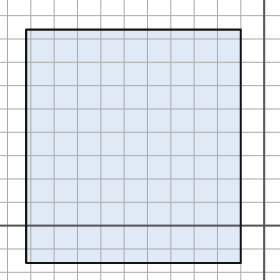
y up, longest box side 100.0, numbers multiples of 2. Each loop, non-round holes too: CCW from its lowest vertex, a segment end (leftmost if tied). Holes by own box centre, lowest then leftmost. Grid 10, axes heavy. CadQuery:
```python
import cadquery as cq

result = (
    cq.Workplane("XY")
    .moveTo(-102.0, -16.0)
    .lineTo(-10.0, -16.0)
    .lineTo(-10.0, 84.0)
    .lineTo(-102.0, 84.0)
    .close()
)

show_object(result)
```